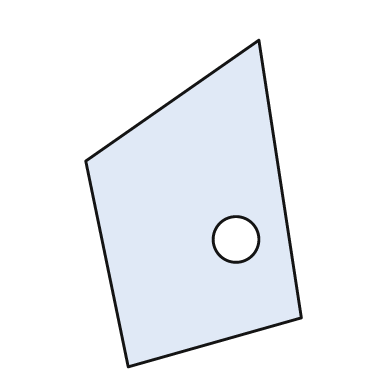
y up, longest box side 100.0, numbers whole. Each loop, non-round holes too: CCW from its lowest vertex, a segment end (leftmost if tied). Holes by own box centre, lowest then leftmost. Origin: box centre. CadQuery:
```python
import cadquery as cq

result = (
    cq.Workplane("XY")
    .moveTo(-20.0, -50.0)
    .lineTo(33.0, -35.0)
    .lineTo(20.0, 50.0)
    .lineTo(-33.0, 13.0)
    .close()
    .moveTo(13.0, -11.0)
    .circle(7.0)
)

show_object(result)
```